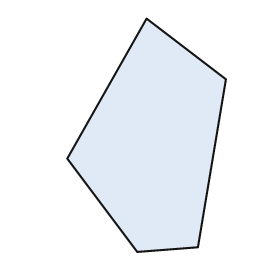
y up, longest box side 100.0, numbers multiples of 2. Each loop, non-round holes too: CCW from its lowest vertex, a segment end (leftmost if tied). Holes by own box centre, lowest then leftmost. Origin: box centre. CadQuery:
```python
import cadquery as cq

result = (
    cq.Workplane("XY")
    .moveTo(-4.0, -50.0)
    .lineTo(22.0, -48.0)
    .lineTo(34.0, 24.0)
    .lineTo(0.0, 50.0)
    .lineTo(-34.0, -10.0)
    .close()
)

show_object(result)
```